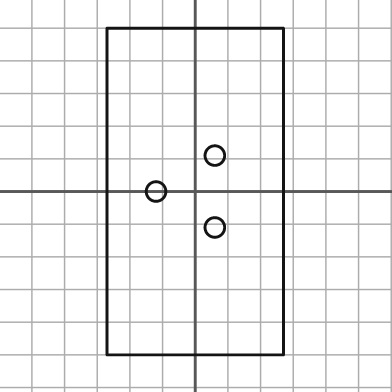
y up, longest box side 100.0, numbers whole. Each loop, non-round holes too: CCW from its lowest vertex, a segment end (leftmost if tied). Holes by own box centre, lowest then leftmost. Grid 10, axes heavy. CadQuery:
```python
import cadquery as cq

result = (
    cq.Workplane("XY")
    .moveTo(-27.0, -50.0)
    .lineTo(27.0, -50.0)
    .lineTo(27.0, 50.0)
    .lineTo(-27.0, 50.0)
    .close()
    .moveTo(6.0, -11.0)
    .circle(3.0)
    .moveTo(-12.0, 0.0)
    .circle(3.0)
    .moveTo(6.0, 11.0)
    .circle(3.0)
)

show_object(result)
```